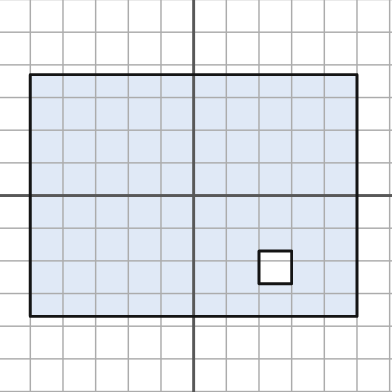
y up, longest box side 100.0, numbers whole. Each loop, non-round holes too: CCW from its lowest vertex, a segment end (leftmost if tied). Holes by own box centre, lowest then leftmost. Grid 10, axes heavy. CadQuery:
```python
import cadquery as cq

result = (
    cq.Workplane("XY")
    .moveTo(-50.0, -37.0)
    .lineTo(50.0, -37.0)
    .lineTo(50.0, 37.0)
    .lineTo(-50.0, 37.0)
    .close()
    .moveTo(20.0, -27.0)
    .lineTo(30.0, -27.0)
    .lineTo(30.0, -17.0)
    .lineTo(20.0, -17.0)
    .close()
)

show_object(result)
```